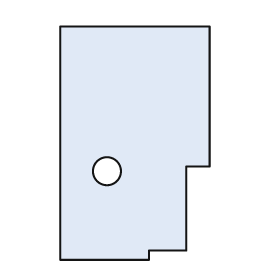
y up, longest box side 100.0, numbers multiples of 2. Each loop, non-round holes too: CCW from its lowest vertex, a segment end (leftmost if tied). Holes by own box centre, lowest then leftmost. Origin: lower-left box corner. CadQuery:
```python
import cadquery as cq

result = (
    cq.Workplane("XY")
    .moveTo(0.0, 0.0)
    .lineTo(38.0, 0.0)
    .lineTo(38.0, 4.0)
    .lineTo(54.0, 4.0)
    .lineTo(54.0, 40.0)
    .lineTo(64.0, 40.0)
    .lineTo(64.0, 100.0)
    .lineTo(0.0, 100.0)
    .close()
    .moveTo(20.0, 38.0)
    .circle(6.0)
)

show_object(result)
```